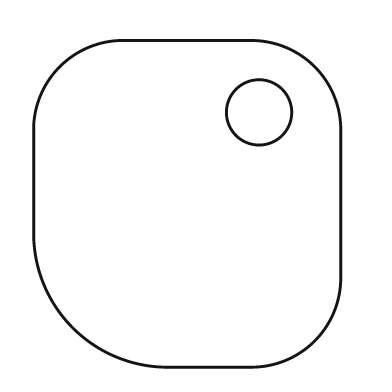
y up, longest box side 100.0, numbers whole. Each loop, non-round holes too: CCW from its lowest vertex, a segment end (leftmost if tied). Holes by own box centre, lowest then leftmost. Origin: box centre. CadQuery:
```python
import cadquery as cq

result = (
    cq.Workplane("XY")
    .moveTo(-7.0, -50.0)
    .lineTo(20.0, -50.0)
    .threePointArc((39.0, -42.0), (47.0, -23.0))
    .lineTo(47.0, 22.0)
    .threePointArc((39.0, 42.0), (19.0, 50.0))
    .lineTo(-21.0, 50.0)
    .threePointArc((-39.0, 42.0), (-47.0, 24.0))
    .lineTo(-47.0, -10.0)
    .threePointArc((-35.0, -38.0), (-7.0, -50.0))
    .close()
    .moveTo(22.0, 28.0)
    .circle(10.0)
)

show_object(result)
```